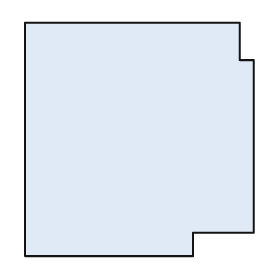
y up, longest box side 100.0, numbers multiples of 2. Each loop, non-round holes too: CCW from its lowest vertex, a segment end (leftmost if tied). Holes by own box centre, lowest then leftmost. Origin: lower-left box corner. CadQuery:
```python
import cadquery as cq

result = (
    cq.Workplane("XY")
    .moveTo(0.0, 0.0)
    .lineTo(72.0, 0.0)
    .lineTo(72.0, 10.0)
    .lineTo(98.0, 10.0)
    .lineTo(98.0, 84.0)
    .lineTo(92.0, 84.0)
    .lineTo(92.0, 100.0)
    .lineTo(0.0, 100.0)
    .close()
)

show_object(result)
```